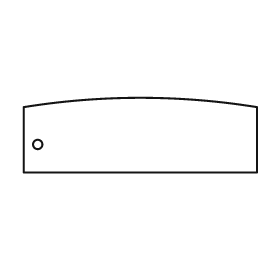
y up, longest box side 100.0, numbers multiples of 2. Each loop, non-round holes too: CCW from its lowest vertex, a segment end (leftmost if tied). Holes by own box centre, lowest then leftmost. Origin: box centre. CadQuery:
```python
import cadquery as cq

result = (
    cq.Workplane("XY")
    .moveTo(-50.0, -16.0)
    .lineTo(50.0, -16.0)
    .lineTo(50.0, 12.0)
    .threePointArc((0.0, 16.0), (-50.0, 12.0))
    .close()
    .moveTo(-44.0, -4.0)
    .circle(2.0)
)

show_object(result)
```